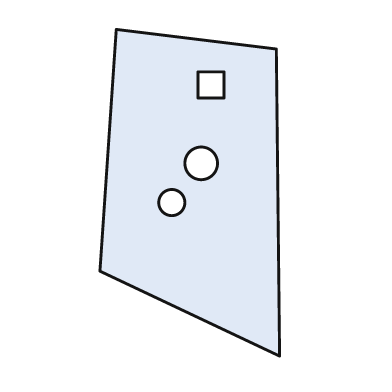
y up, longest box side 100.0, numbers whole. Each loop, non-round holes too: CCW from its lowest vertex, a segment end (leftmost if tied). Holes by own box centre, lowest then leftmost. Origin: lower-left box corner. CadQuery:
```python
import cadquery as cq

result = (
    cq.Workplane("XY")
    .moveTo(55.0, 0.0)
    .lineTo(54.0, 94.0)
    .lineTo(5.0, 100.0)
    .lineTo(0.0, 26.0)
    .close()
    .moveTo(22.0, 47.0)
    .circle(4.0)
    .moveTo(31.0, 59.0)
    .circle(5.0)
    .moveTo(30.0, 79.0)
    .lineTo(38.0, 79.0)
    .lineTo(38.0, 87.0)
    .lineTo(30.0, 87.0)
    .close()
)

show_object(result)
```